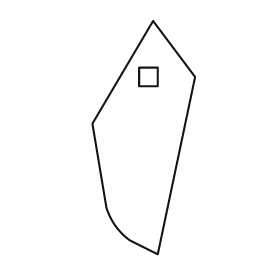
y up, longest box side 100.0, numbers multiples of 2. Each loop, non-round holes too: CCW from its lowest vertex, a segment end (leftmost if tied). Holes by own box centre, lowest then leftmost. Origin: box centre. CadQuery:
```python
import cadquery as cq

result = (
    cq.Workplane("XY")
    .moveTo(6.0, -50.0)
    .lineTo(22.0, 26.0)
    .lineTo(4.0, 50.0)
    .lineTo(-22.0, 6.0)
    .lineTo(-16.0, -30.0)
    .threePointArc((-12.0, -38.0), (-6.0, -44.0))
    .close()
    .moveTo(-2.0, 22.0)
    .lineTo(6.0, 22.0)
    .lineTo(6.0, 30.0)
    .lineTo(-2.0, 30.0)
    .close()
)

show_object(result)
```